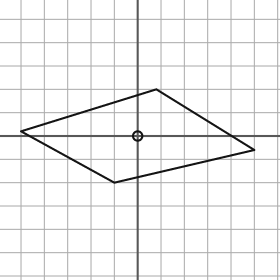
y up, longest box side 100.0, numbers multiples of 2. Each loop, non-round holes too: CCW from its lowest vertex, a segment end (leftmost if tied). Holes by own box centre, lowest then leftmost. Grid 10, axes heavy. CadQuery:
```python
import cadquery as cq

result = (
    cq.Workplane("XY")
    .moveTo(-10.0, -20.0)
    .lineTo(50.0, -6.0)
    .lineTo(8.0, 20.0)
    .lineTo(-50.0, 2.0)
    .close()
    .moveTo(0.0, 0.0)
    .circle(2.0)
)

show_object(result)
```